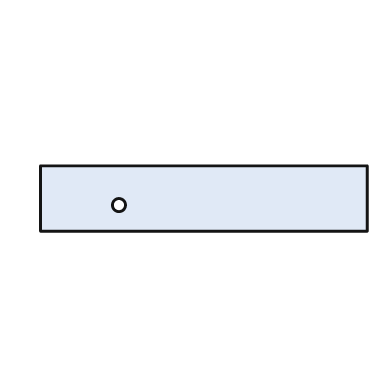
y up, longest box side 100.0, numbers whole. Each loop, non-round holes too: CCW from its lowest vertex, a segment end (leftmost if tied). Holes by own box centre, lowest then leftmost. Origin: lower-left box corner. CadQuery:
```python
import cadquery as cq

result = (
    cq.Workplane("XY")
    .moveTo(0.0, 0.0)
    .lineTo(100.0, 0.0)
    .lineTo(100.0, 20.0)
    .lineTo(0.0, 20.0)
    .close()
    .moveTo(24.0, 8.0)
    .circle(2.0)
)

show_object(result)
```